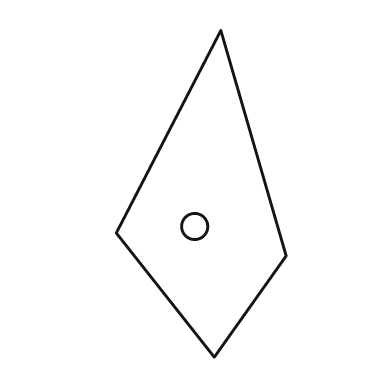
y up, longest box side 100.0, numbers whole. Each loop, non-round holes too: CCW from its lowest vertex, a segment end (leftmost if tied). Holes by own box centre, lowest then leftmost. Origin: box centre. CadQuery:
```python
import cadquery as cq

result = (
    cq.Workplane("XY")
    .moveTo(4.0, -50.0)
    .lineTo(26.0, -19.0)
    .lineTo(6.0, 50.0)
    .lineTo(-26.0, -12.0)
    .close()
    .moveTo(-2.0, -10.0)
    .circle(4.0)
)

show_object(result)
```